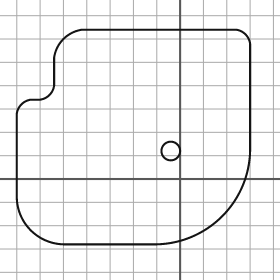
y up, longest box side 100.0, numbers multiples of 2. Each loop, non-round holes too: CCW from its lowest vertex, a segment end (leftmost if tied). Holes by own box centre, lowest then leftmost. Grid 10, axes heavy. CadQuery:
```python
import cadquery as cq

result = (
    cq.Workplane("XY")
    .moveTo(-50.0, -28.0)
    .lineTo(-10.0, -28.0)
    .threePointArc((18.0, -16.0), (30.0, 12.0))
    .lineTo(30.0, 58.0)
    .threePointArc((28.0, 62.0), (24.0, 64.0))
    .lineTo(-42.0, 64.0)
    .threePointArc((-50.0, 60.0), (-54.0, 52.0))
    .lineTo(-54.0, 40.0)
    .threePointArc((-56.0, 36.0), (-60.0, 34.0))
    .lineTo(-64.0, 34.0)
    .threePointArc((-68.0, 32.0), (-70.0, 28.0))
    .lineTo(-70.0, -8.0)
    .threePointArc((-64.0, -22.0), (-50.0, -28.0))
    .close()
    .moveTo(-4.0, 12.0)
    .circle(4.0)
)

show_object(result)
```